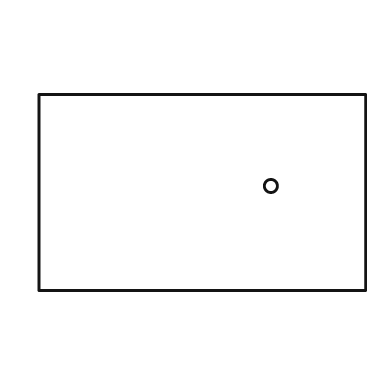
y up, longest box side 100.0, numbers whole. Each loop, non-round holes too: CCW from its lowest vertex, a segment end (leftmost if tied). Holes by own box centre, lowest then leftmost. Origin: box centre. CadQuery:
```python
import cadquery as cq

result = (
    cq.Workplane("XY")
    .moveTo(-50.0, -30.0)
    .lineTo(50.0, -30.0)
    .lineTo(50.0, 30.0)
    .lineTo(-50.0, 30.0)
    .close()
    .moveTo(21.0, 2.0)
    .circle(2.0)
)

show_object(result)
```